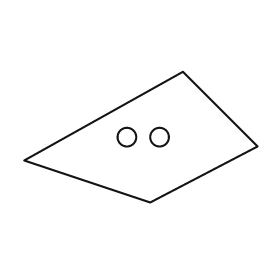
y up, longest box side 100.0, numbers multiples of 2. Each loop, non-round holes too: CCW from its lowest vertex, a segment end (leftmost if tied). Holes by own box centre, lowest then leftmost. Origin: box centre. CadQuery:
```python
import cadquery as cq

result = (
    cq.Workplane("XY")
    .moveTo(4.0, -28.0)
    .lineTo(50.0, -4.0)
    .lineTo(18.0, 28.0)
    .lineTo(-50.0, -10.0)
    .close()
    .moveTo(-6.0, 0.0)
    .circle(4.0)
    .moveTo(8.0, 0.0)
    .circle(4.0)
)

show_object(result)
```